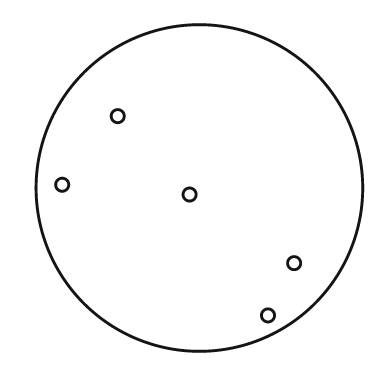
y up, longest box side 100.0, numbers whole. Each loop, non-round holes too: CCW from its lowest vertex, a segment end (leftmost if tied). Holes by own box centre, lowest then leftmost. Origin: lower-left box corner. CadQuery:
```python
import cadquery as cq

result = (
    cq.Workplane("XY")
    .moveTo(50.0, 50.0)
    .circle(50.0)
    .moveTo(71.0, 11.0)
    .circle(2.0)
    .moveTo(79.0, 27.0)
    .circle(2.0)
    .moveTo(47.0, 48.0)
    .circle(2.0)
    .moveTo(8.0, 51.0)
    .circle(2.0)
    .moveTo(25.0, 72.0)
    .circle(2.0)
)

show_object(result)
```